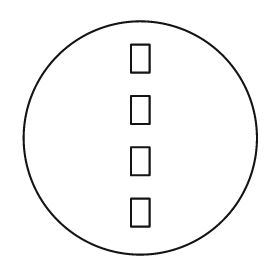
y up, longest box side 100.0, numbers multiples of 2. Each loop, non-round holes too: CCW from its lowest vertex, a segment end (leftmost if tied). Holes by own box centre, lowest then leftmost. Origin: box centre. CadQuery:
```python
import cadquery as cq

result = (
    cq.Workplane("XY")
    .moveTo(0.0, 0.0)
    .circle(50.0)
    .moveTo(-4.0, -38.0)
    .lineTo(4.0, -38.0)
    .lineTo(4.0, -26.0)
    .lineTo(-4.0, -26.0)
    .close()
    .moveTo(-4.0, -16.0)
    .lineTo(4.0, -16.0)
    .lineTo(4.0, -4.0)
    .lineTo(-4.0, -4.0)
    .close()
    .moveTo(-4.0, 6.0)
    .lineTo(4.0, 6.0)
    .lineTo(4.0, 18.0)
    .lineTo(-4.0, 18.0)
    .close()
    .moveTo(-4.0, 28.0)
    .lineTo(4.0, 28.0)
    .lineTo(4.0, 40.0)
    .lineTo(-4.0, 40.0)
    .close()
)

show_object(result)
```